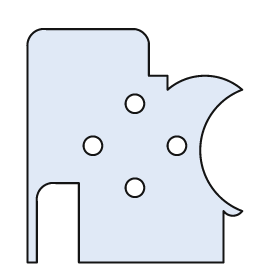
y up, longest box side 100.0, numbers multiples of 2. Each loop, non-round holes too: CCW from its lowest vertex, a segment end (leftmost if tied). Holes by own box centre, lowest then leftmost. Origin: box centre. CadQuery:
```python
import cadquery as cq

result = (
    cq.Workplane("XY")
    .moveTo(-46.0, -50.0)
    .lineTo(-42.0, -50.0)
    .lineTo(-42.0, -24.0)
    .threePointArc((-40.0, -18.0), (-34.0, -16.0))
    .lineTo(-24.0, -16.0)
    .lineTo(-24.0, -50.0)
    .lineTo(38.0, -50.0)
    .lineTo(38.0, -28.0)
    .threePointArc((42.0, -30.0), (46.0, -28.0))
    .threePointArc((28.0, -2.0), (46.0, 24.0))
    .threePointArc((30.0, 30.0), (14.0, 24.0))
    .lineTo(14.0, 30.0)
    .lineTo(6.0, 30.0)
    .lineTo(6.0, 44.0)
    .threePointArc((4.0, 48.0), (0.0, 50.0))
    .lineTo(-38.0, 50.0)
    .threePointArc((-44.0, 48.0), (-46.0, 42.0))
    .close()
    .moveTo(0.0, -18.0)
    .circle(4.0)
    .moveTo(-18.0, 0.0)
    .circle(4.0)
    .moveTo(18.0, 0.0)
    .circle(4.0)
    .moveTo(0.0, 18.0)
    .circle(4.0)
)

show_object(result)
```